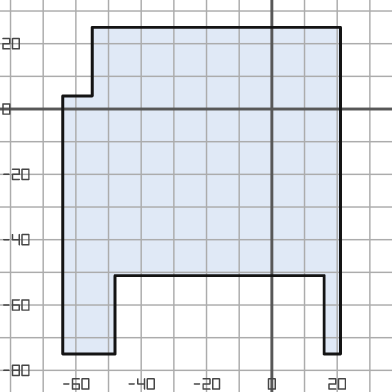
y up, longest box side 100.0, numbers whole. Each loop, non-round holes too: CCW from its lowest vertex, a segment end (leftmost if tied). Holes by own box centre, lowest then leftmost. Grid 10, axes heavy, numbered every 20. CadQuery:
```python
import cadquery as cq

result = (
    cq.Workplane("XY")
    .moveTo(-64.0, -75.0)
    .lineTo(-48.0, -75.0)
    .lineTo(-48.0, -51.0)
    .lineTo(16.0, -51.0)
    .lineTo(16.0, -75.0)
    .lineTo(21.0, -75.0)
    .lineTo(21.0, 25.0)
    .lineTo(-55.0, 25.0)
    .lineTo(-55.0, 4.0)
    .lineTo(-64.0, 4.0)
    .close()
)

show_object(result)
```